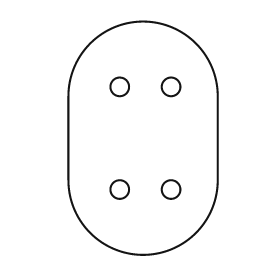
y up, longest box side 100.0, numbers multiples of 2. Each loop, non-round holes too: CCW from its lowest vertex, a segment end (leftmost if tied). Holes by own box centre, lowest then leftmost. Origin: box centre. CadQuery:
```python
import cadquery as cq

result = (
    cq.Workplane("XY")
    .moveTo(-32.0, -18.0)
    .threePointArc((0.0, -50.0), (32.0, -18.0))
    .lineTo(32.0, 18.0)
    .threePointArc((0.0, 50.0), (-32.0, 18.0))
    .close()
    .moveTo(-10.0, -22.0)
    .circle(4.0)
    .moveTo(12.0, -22.0)
    .circle(4.0)
    .moveTo(-10.0, 22.0)
    .circle(4.0)
    .moveTo(12.0, 22.0)
    .circle(4.0)
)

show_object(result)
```